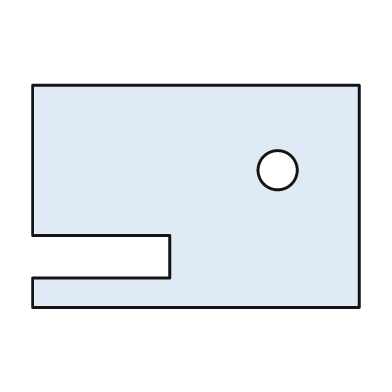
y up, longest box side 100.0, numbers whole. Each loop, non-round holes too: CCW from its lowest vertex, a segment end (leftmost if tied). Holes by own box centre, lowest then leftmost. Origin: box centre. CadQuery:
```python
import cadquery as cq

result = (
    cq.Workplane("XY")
    .moveTo(-50.0, -34.0)
    .lineTo(50.0, -34.0)
    .lineTo(50.0, 34.0)
    .lineTo(-50.0, 34.0)
    .lineTo(-50.0, -12.0)
    .lineTo(-8.0, -12.0)
    .lineTo(-8.0, -25.0)
    .lineTo(-50.0, -25.0)
    .close()
    .moveTo(25.0, 8.0)
    .circle(6.0)
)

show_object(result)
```